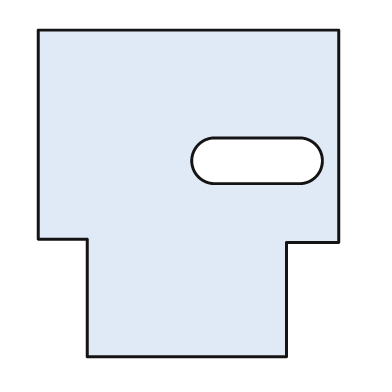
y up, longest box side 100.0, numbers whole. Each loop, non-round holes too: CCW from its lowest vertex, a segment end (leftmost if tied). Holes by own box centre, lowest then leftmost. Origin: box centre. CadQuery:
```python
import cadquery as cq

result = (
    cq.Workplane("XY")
    .moveTo(-31.0, -50.0)
    .lineTo(30.0, -50.0)
    .lineTo(30.0, -15.0)
    .lineTo(46.0, -15.0)
    .lineTo(46.0, 50.0)
    .lineTo(-46.0, 50.0)
    .lineTo(-46.0, -14.0)
    .lineTo(-31.0, -14.0)
    .close()
    .moveTo(8.0, 3.0)
    .lineTo(34.0, 3.0)
    .threePointArc((41.0, 10.0), (34.0, 17.0))
    .lineTo(8.0, 17.0)
    .threePointArc((1.0, 10.0), (8.0, 3.0))
    .close()
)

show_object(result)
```